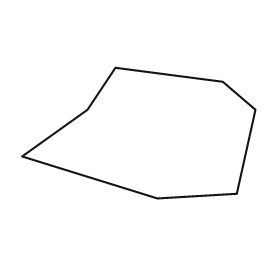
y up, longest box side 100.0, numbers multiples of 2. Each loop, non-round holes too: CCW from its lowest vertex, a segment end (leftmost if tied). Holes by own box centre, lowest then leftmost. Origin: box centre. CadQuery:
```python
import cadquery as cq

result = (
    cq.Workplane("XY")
    .moveTo(8.0, -28.0)
    .lineTo(42.0, -26.0)
    .lineTo(50.0, 10.0)
    .lineTo(36.0, 22.0)
    .lineTo(-10.0, 28.0)
    .lineTo(-22.0, 10.0)
    .lineTo(-50.0, -10.0)
    .close()
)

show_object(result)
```